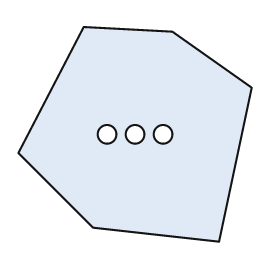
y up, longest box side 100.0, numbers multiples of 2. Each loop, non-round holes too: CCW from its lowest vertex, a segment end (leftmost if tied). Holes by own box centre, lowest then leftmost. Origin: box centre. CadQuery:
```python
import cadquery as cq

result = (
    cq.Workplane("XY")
    .moveTo(36.0, -46.0)
    .lineTo(50.0, 20.0)
    .lineTo(16.0, 44.0)
    .lineTo(-22.0, 46.0)
    .lineTo(-50.0, -8.0)
    .lineTo(-18.0, -40.0)
    .close()
    .moveTo(-12.0, 0.0)
    .circle(4.0)
    .moveTo(0.0, 0.0)
    .circle(4.0)
    .moveTo(12.0, 0.0)
    .circle(4.0)
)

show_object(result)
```